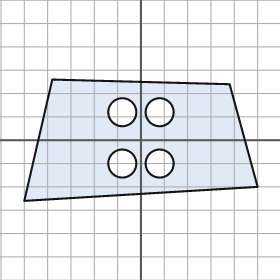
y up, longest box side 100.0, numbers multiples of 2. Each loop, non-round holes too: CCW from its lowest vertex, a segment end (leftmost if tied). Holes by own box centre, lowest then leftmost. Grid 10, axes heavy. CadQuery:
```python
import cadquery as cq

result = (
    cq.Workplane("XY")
    .moveTo(-50.0, -26.0)
    .lineTo(50.0, -20.0)
    .lineTo(38.0, 24.0)
    .lineTo(-38.0, 26.0)
    .close()
    .moveTo(-8.0, -10.0)
    .circle(6.0)
    .moveTo(8.0, -10.0)
    .circle(6.0)
    .moveTo(-8.0, 12.0)
    .circle(6.0)
    .moveTo(8.0, 12.0)
    .circle(6.0)
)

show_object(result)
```